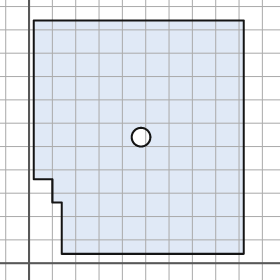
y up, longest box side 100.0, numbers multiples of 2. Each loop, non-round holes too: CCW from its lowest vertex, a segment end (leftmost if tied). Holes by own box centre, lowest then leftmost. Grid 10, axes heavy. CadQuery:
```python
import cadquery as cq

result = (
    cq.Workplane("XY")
    .moveTo(14.0, 4.0)
    .lineTo(92.0, 4.0)
    .lineTo(92.0, 104.0)
    .lineTo(2.0, 104.0)
    .lineTo(2.0, 36.0)
    .lineTo(10.0, 36.0)
    .lineTo(10.0, 26.0)
    .lineTo(14.0, 26.0)
    .close()
    .moveTo(48.0, 54.0)
    .circle(4.0)
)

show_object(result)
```